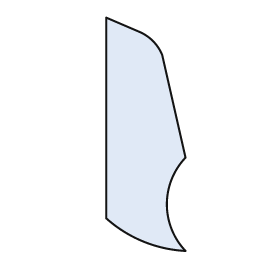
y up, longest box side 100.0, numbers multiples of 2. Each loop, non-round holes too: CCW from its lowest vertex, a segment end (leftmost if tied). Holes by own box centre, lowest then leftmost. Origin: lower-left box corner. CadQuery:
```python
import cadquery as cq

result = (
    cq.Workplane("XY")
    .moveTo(34.0, 0.0)
    .threePointArc((26.0, 20.0), (34.0, 40.0))
    .lineTo(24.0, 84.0)
    .threePointArc((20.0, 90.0), (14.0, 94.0))
    .lineTo(0.0, 100.0)
    .lineTo(0.0, 14.0)
    .threePointArc((16.0, 4.0), (34.0, 0.0))
    .close()
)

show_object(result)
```